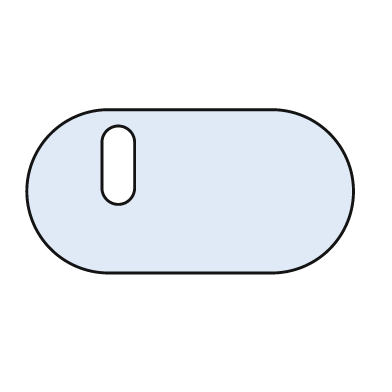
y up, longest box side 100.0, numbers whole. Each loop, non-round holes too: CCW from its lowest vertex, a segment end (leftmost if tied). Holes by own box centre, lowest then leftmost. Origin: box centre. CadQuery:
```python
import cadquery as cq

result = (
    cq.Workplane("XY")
    .moveTo(-25.0, -25.0)
    .lineTo(25.0, -25.0)
    .threePointArc((50.0, 0.0), (25.0, 25.0))
    .lineTo(-25.0, 25.0)
    .threePointArc((-50.0, 0.0), (-25.0, -25.0))
    .close()
    .moveTo(-27.0, 1.0)
    .threePointArc((-22.0, -4.0), (-17.0, 1.0))
    .lineTo(-17.0, 15.0)
    .threePointArc((-22.0, 20.0), (-27.0, 15.0))
    .close()
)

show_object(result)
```